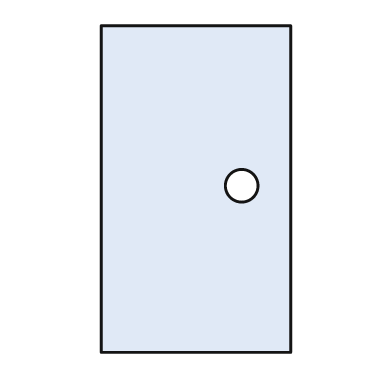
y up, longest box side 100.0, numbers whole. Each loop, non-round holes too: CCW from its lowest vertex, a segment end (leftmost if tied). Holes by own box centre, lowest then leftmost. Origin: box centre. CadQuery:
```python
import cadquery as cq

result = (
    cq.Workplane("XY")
    .moveTo(-29.0, -50.0)
    .lineTo(29.0, -50.0)
    .lineTo(29.0, 50.0)
    .lineTo(-29.0, 50.0)
    .close()
    .moveTo(14.0, 1.0)
    .circle(5.0)
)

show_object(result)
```